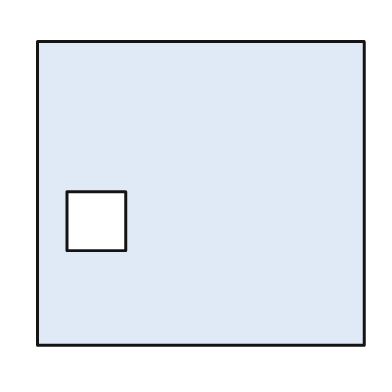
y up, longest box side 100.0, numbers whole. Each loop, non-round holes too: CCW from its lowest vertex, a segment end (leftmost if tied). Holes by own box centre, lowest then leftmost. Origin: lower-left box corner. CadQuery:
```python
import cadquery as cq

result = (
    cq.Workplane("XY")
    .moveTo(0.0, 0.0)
    .lineTo(100.0, 0.0)
    .lineTo(100.0, 93.0)
    .lineTo(0.0, 93.0)
    .close()
    .moveTo(9.0, 29.0)
    .lineTo(27.0, 29.0)
    .lineTo(27.0, 47.0)
    .lineTo(9.0, 47.0)
    .close()
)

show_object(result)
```